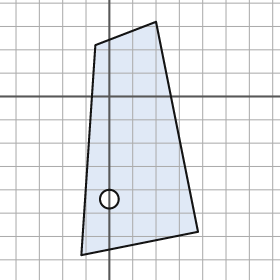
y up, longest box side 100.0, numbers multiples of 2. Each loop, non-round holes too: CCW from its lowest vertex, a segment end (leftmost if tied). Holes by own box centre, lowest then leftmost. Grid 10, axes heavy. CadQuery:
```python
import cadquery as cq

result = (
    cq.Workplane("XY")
    .moveTo(-12.0, -68.0)
    .lineTo(38.0, -58.0)
    .lineTo(20.0, 32.0)
    .lineTo(-6.0, 22.0)
    .close()
    .moveTo(0.0, -44.0)
    .circle(4.0)
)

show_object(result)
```